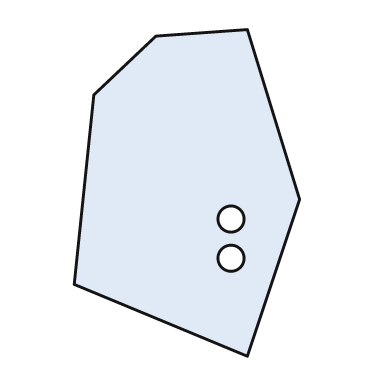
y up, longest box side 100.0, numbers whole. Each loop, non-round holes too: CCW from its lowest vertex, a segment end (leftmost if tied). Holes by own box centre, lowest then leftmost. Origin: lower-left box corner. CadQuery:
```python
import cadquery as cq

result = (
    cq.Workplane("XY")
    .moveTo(53.0, 0.0)
    .lineTo(69.0, 48.0)
    .lineTo(53.0, 100.0)
    .lineTo(25.0, 98.0)
    .lineTo(6.0, 80.0)
    .lineTo(0.0, 22.0)
    .close()
    .moveTo(48.0, 30.0)
    .circle(4.0)
    .moveTo(48.0, 42.0)
    .circle(4.0)
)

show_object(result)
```